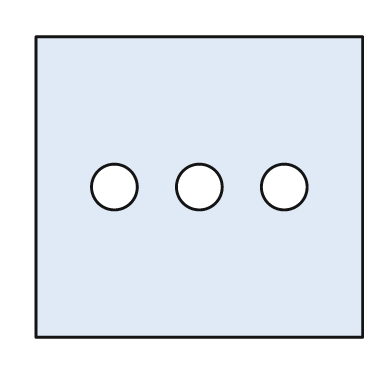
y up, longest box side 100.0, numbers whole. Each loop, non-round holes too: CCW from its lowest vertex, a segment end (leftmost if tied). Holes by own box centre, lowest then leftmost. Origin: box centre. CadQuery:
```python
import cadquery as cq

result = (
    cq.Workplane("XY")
    .moveTo(-50.0, -46.0)
    .lineTo(50.0, -46.0)
    .lineTo(50.0, 46.0)
    .lineTo(-50.0, 46.0)
    .close()
    .moveTo(-26.0, 0.0)
    .circle(7.0)
    .moveTo(0.0, 0.0)
    .circle(7.0)
    .moveTo(26.0, 0.0)
    .circle(7.0)
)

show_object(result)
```